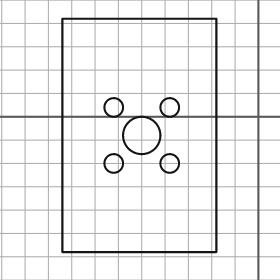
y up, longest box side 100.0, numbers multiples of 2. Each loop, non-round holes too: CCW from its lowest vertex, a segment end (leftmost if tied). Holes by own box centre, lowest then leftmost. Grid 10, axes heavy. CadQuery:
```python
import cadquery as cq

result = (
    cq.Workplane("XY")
    .moveTo(-84.0, -58.0)
    .lineTo(-18.0, -58.0)
    .lineTo(-18.0, 42.0)
    .lineTo(-84.0, 42.0)
    .close()
    .moveTo(-62.0, -20.0)
    .circle(4.0)
    .moveTo(-38.0, -20.0)
    .circle(4.0)
    .moveTo(-50.0, -8.0)
    .circle(8.0)
    .moveTo(-62.0, 4.0)
    .circle(4.0)
    .moveTo(-38.0, 4.0)
    .circle(4.0)
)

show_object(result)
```